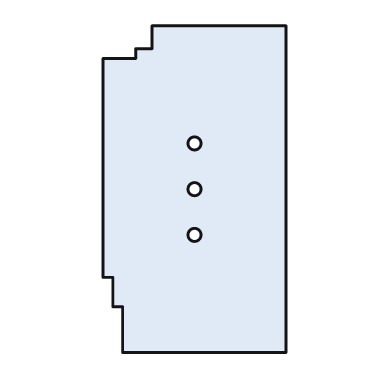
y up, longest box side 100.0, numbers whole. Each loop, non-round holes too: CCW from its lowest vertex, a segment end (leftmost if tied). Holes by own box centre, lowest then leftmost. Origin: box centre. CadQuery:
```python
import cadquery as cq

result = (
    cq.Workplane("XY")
    .moveTo(-22.0, -50.0)
    .lineTo(28.0, -50.0)
    .lineTo(28.0, 50.0)
    .lineTo(-13.0, 50.0)
    .lineTo(-13.0, 43.0)
    .lineTo(-18.0, 43.0)
    .lineTo(-18.0, 40.0)
    .lineTo(-28.0, 40.0)
    .lineTo(-28.0, -27.0)
    .lineTo(-25.0, -27.0)
    .lineTo(-25.0, -36.0)
    .lineTo(-22.0, -36.0)
    .close()
    .moveTo(0.0, -14.0)
    .circle(2.0)
    .moveTo(0.0, 0.0)
    .circle(2.0)
    .moveTo(0.0, 14.0)
    .circle(2.0)
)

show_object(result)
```